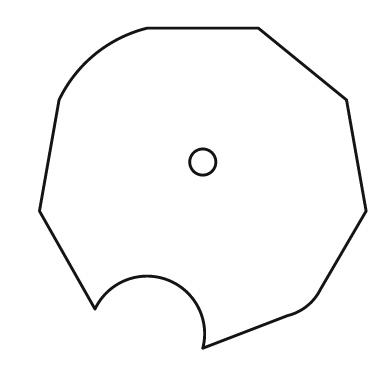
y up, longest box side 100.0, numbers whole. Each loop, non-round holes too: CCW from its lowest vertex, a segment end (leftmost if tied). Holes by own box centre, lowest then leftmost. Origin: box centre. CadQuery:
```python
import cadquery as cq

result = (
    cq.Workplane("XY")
    .moveTo(0.0, -49.0)
    .lineTo(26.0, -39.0)
    .threePointArc((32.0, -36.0), (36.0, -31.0))
    .lineTo(50.0, -7.0)
    .lineTo(44.0, 27.0)
    .lineTo(17.0, 49.0)
    .lineTo(-17.0, 49.0)
    .threePointArc((-33.0, 41.0), (-44.0, 27.0))
    .lineTo(-50.0, -7.0)
    .lineTo(-33.0, -37.0)
    .threePointArc((-11.0, -28.0), (0.0, -49.0))
    .close()
    .moveTo(0.0, 8.0)
    .circle(4.0)
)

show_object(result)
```